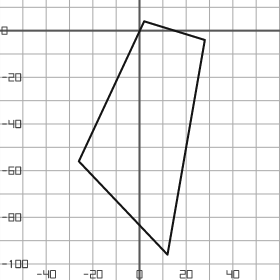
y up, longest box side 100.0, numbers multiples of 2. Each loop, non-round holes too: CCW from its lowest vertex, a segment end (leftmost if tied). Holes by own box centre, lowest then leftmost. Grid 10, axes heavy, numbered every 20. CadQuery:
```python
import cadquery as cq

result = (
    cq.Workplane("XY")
    .moveTo(12.0, -96.0)
    .lineTo(28.0, -4.0)
    .lineTo(2.0, 4.0)
    .lineTo(-26.0, -56.0)
    .close()
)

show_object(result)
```